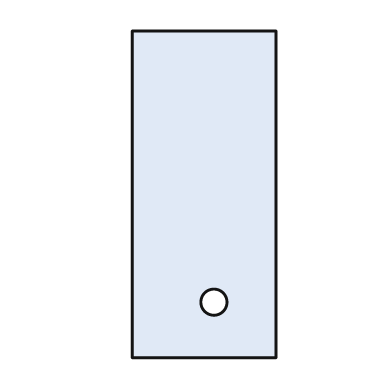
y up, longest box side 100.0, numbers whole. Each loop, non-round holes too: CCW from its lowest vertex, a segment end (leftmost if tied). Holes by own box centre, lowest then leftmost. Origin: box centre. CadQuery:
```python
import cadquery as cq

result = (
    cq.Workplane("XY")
    .moveTo(-22.0, -50.0)
    .lineTo(22.0, -50.0)
    .lineTo(22.0, 50.0)
    .lineTo(-22.0, 50.0)
    .close()
    .moveTo(3.0, -33.0)
    .circle(4.0)
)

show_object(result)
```